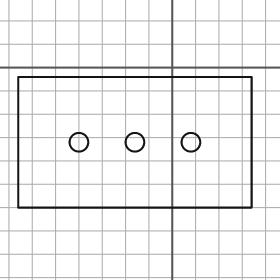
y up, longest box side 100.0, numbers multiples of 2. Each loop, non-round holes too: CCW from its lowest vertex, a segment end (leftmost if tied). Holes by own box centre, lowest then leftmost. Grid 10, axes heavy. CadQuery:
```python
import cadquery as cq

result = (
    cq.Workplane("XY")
    .moveTo(-66.0, -60.0)
    .lineTo(34.0, -60.0)
    .lineTo(34.0, -4.0)
    .lineTo(-66.0, -4.0)
    .close()
    .moveTo(-40.0, -32.0)
    .circle(4.0)
    .moveTo(-16.0, -32.0)
    .circle(4.0)
    .moveTo(8.0, -32.0)
    .circle(4.0)
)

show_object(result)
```